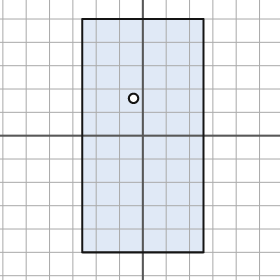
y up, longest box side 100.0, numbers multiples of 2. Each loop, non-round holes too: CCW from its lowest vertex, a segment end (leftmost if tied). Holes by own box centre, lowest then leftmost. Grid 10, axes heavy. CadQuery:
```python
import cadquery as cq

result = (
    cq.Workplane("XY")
    .moveTo(-26.0, -50.0)
    .lineTo(26.0, -50.0)
    .lineTo(26.0, 50.0)
    .lineTo(-26.0, 50.0)
    .close()
    .moveTo(-4.0, 16.0)
    .circle(2.0)
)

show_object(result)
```